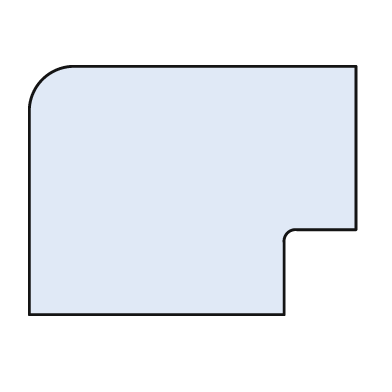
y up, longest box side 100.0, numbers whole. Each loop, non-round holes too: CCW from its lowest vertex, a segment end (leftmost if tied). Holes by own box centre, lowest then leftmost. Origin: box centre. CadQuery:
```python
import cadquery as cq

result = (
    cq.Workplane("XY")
    .moveTo(-50.0, -38.0)
    .lineTo(28.0, -38.0)
    .lineTo(28.0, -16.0)
    .threePointArc((29.0, -13.0), (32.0, -12.0))
    .lineTo(50.0, -12.0)
    .lineTo(50.0, 38.0)
    .lineTo(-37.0, 38.0)
    .threePointArc((-46.0, 34.0), (-50.0, 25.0))
    .close()
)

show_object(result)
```